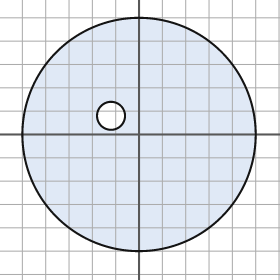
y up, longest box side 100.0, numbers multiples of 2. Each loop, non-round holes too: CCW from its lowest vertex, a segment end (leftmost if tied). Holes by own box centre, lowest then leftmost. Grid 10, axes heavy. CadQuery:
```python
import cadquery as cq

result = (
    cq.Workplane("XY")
    .moveTo(0.0, 0.0)
    .circle(50.0)
    .moveTo(-12.0, 8.0)
    .circle(6.0)
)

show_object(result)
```